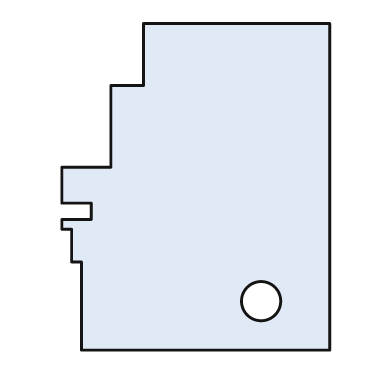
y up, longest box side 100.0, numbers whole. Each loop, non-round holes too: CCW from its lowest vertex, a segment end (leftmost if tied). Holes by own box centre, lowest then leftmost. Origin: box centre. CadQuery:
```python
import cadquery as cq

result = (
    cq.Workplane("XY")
    .moveTo(-35.0, -50.0)
    .lineTo(41.0, -50.0)
    .lineTo(41.0, 50.0)
    .lineTo(-16.0, 50.0)
    .lineTo(-16.0, 31.0)
    .lineTo(-26.0, 31.0)
    .lineTo(-26.0, 6.0)
    .lineTo(-41.0, 6.0)
    .lineTo(-41.0, -5.0)
    .lineTo(-32.0, -5.0)
    .lineTo(-32.0, -10.0)
    .lineTo(-41.0, -10.0)
    .lineTo(-41.0, -13.0)
    .lineTo(-38.0, -13.0)
    .lineTo(-38.0, -23.0)
    .lineTo(-35.0, -23.0)
    .close()
    .moveTo(20.0, -35.0)
    .circle(6.0)
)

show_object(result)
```